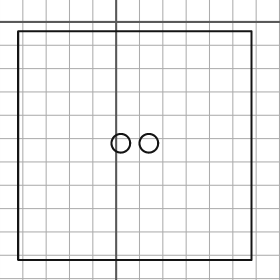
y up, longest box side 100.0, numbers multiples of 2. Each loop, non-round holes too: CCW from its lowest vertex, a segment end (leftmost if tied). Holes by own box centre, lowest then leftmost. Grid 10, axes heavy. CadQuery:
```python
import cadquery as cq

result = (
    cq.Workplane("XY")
    .moveTo(-42.0, -102.0)
    .lineTo(58.0, -102.0)
    .lineTo(58.0, -4.0)
    .lineTo(-42.0, -4.0)
    .close()
    .moveTo(2.0, -52.0)
    .circle(4.0)
    .moveTo(14.0, -52.0)
    .circle(4.0)
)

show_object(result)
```